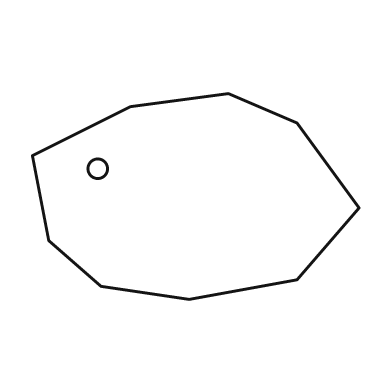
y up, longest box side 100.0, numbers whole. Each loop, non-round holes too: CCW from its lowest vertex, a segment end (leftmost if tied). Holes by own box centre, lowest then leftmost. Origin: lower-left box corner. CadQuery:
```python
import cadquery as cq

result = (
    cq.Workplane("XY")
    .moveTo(48.0, 0.0)
    .lineTo(81.0, 6.0)
    .lineTo(100.0, 28.0)
    .lineTo(81.0, 54.0)
    .lineTo(60.0, 63.0)
    .lineTo(30.0, 59.0)
    .lineTo(0.0, 44.0)
    .lineTo(5.0, 18.0)
    .lineTo(21.0, 4.0)
    .close()
    .moveTo(20.0, 40.0)
    .circle(3.0)
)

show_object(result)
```